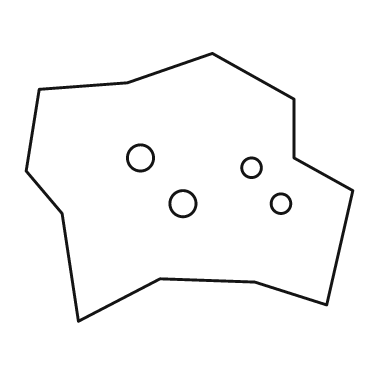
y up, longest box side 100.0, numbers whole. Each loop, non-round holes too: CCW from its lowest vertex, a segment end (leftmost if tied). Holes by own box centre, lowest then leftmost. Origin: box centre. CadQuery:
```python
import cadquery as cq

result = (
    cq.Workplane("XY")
    .moveTo(-34.0, -41.0)
    .lineTo(-9.0, -28.0)
    .lineTo(20.0, -29.0)
    .lineTo(42.0, -36.0)
    .lineTo(50.0, -1.0)
    .lineTo(32.0, 9.0)
    .lineTo(32.0, 27.0)
    .lineTo(7.0, 41.0)
    .lineTo(-19.0, 32.0)
    .lineTo(-46.0, 30.0)
    .lineTo(-50.0, 5.0)
    .lineTo(-39.0, -8.0)
    .close()
    .moveTo(-2.0, -5.0)
    .circle(4.0)
    .moveTo(28.0, -5.0)
    .circle(3.0)
    .moveTo(19.0, 6.0)
    .circle(3.0)
    .moveTo(-15.0, 9.0)
    .circle(4.0)
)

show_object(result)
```